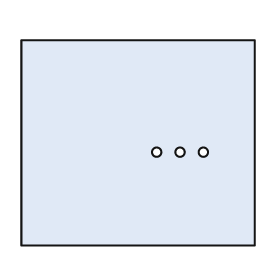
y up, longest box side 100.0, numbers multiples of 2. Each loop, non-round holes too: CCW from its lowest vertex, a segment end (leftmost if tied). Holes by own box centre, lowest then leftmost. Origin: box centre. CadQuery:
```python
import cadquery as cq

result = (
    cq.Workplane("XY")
    .moveTo(-50.0, -44.0)
    .lineTo(50.0, -44.0)
    .lineTo(50.0, 44.0)
    .lineTo(-50.0, 44.0)
    .close()
    .moveTo(8.0, -4.0)
    .circle(2.0)
    .moveTo(18.0, -4.0)
    .circle(2.0)
    .moveTo(28.0, -4.0)
    .circle(2.0)
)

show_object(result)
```